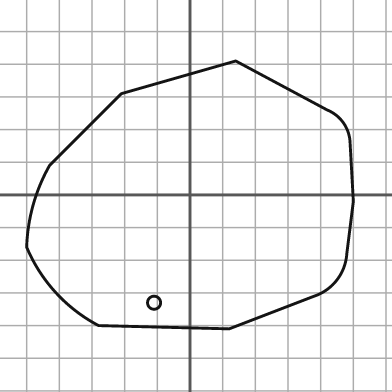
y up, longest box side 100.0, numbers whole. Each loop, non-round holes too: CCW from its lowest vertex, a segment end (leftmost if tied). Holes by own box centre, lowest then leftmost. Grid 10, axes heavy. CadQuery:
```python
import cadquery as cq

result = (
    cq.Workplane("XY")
    .moveTo(12.0, -41.0)
    .lineTo(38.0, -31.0)
    .threePointArc((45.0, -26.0), (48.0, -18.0))
    .lineTo(50.0, -2.0)
    .lineTo(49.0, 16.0)
    .threePointArc((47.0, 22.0), (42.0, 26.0))
    .lineTo(14.0, 41.0)
    .lineTo(-21.0, 31.0)
    .lineTo(-43.0, 9.0)
    .threePointArc((-48.0, -3.0), (-50.0, -16.0))
    .threePointArc((-41.0, -30.0), (-28.0, -40.0))
    .close()
    .moveTo(-11.0, -33.0)
    .circle(2.0)
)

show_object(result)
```